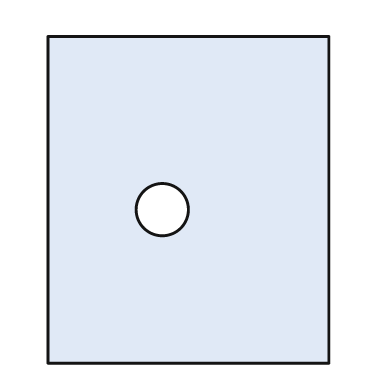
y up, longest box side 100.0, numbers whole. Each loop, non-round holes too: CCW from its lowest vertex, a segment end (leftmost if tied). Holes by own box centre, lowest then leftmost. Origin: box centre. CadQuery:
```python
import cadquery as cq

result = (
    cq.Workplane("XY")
    .moveTo(-43.0, -50.0)
    .lineTo(43.0, -50.0)
    .lineTo(43.0, 50.0)
    .lineTo(-43.0, 50.0)
    .close()
    .moveTo(-8.0, -3.0)
    .circle(8.0)
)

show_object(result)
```